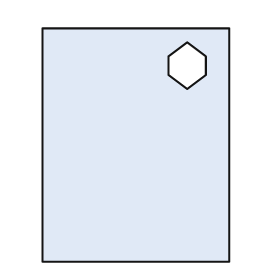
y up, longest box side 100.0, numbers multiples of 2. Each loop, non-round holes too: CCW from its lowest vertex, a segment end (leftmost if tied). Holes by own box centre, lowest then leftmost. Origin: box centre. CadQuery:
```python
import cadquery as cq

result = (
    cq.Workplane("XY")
    .moveTo(-40.0, -50.0)
    .lineTo(40.0, -50.0)
    .lineTo(40.0, 50.0)
    .lineTo(-40.0, 50.0)
    .close()
    .moveTo(22.0, 24.0)
    .lineTo(30.0, 30.0)
    .lineTo(30.0, 38.0)
    .lineTo(22.0, 44.0)
    .lineTo(14.0, 38.0)
    .lineTo(14.0, 30.0)
    .close()
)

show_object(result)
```